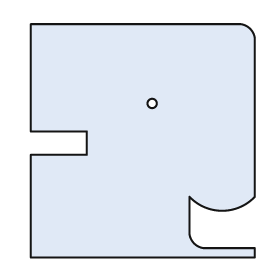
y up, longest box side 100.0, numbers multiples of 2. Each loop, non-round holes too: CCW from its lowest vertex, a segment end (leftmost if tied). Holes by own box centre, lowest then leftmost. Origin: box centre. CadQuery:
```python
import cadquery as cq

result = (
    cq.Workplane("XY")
    .moveTo(-48.0, -50.0)
    .lineTo(48.0, -50.0)
    .lineTo(48.0, -46.0)
    .lineTo(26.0, -46.0)
    .threePointArc((22.0, -44.0), (20.0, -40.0))
    .lineTo(20.0, -24.0)
    .threePointArc((34.0, -30.0), (48.0, -24.0))
    .lineTo(48.0, 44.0)
    .threePointArc((46.0, 48.0), (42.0, 50.0))
    .lineTo(-48.0, 50.0)
    .lineTo(-48.0, 4.0)
    .lineTo(-24.0, 4.0)
    .lineTo(-24.0, -6.0)
    .lineTo(-48.0, -6.0)
    .close()
    .moveTo(4.0, 16.0)
    .circle(2.0)
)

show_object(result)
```